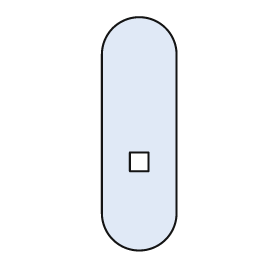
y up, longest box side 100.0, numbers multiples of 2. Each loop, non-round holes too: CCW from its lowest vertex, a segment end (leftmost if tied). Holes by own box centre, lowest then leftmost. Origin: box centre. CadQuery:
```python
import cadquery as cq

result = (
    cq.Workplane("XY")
    .moveTo(-16.0, -34.0)
    .threePointArc((0.0, -50.0), (16.0, -34.0))
    .lineTo(16.0, 34.0)
    .threePointArc((0.0, 50.0), (-16.0, 34.0))
    .close()
    .moveTo(-4.0, -16.0)
    .lineTo(4.0, -16.0)
    .lineTo(4.0, -8.0)
    .lineTo(-4.0, -8.0)
    .close()
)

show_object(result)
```